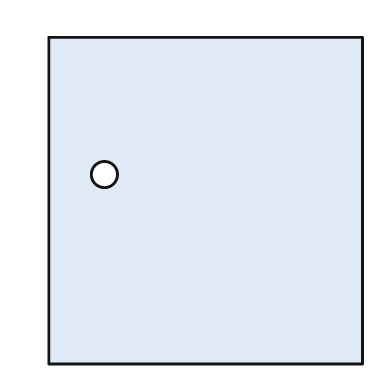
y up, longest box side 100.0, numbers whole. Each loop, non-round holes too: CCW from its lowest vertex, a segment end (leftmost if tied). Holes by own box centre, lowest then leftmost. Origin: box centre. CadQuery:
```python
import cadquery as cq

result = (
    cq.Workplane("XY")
    .moveTo(-48.0, -50.0)
    .lineTo(48.0, -50.0)
    .lineTo(48.0, 50.0)
    .lineTo(-48.0, 50.0)
    .close()
    .moveTo(-31.0, 8.0)
    .circle(4.0)
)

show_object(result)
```